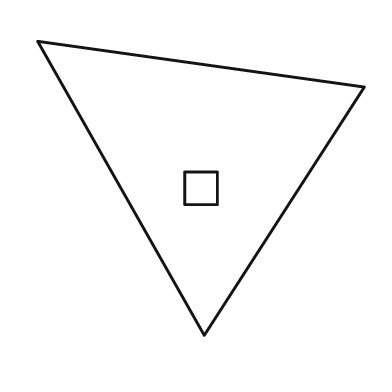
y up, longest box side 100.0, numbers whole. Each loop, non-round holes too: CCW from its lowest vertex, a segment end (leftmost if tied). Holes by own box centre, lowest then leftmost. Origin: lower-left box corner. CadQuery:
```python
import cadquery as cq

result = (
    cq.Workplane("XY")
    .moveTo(51.0, 0.0)
    .lineTo(100.0, 76.0)
    .lineTo(0.0, 90.0)
    .close()
    .moveTo(45.0, 40.0)
    .lineTo(55.0, 40.0)
    .lineTo(55.0, 50.0)
    .lineTo(45.0, 50.0)
    .close()
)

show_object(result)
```